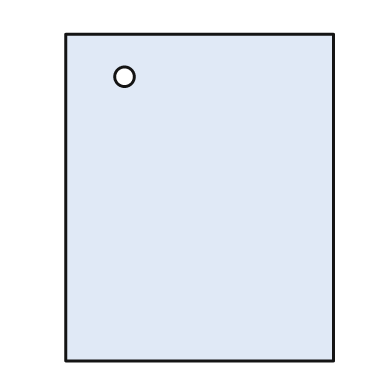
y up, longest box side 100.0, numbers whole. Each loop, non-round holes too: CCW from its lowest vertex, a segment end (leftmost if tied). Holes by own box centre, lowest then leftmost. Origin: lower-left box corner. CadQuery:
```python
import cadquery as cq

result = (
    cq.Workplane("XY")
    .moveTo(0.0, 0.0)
    .lineTo(82.0, 0.0)
    .lineTo(82.0, 100.0)
    .lineTo(0.0, 100.0)
    .close()
    .moveTo(18.0, 87.0)
    .circle(3.0)
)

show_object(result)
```